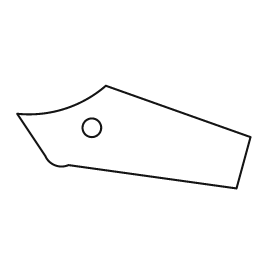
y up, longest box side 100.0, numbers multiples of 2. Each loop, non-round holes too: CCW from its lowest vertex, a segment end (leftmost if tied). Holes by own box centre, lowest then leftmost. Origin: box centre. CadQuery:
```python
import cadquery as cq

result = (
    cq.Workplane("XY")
    .moveTo(44.0, -22.0)
    .lineTo(50.0, 0.0)
    .lineTo(-12.0, 22.0)
    .threePointArc((-30.0, 12.0), (-50.0, 10.0))
    .lineTo(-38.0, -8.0)
    .threePointArc((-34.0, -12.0), (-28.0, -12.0))
    .close()
    .moveTo(-18.0, 4.0)
    .circle(4.0)
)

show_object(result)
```